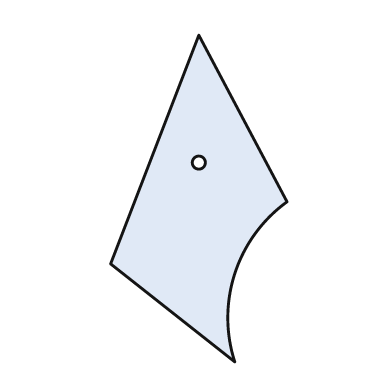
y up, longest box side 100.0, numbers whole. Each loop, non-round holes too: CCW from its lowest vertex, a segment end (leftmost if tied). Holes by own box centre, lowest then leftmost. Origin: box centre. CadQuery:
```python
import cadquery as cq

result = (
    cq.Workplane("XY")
    .moveTo(11.0, -50.0)
    .threePointArc((11.0, -23.0), (27.0, -1.0))
    .lineTo(0.0, 50.0)
    .lineTo(-27.0, -20.0)
    .close()
    .moveTo(0.0, 11.0)
    .circle(2.0)
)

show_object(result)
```